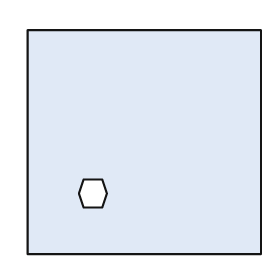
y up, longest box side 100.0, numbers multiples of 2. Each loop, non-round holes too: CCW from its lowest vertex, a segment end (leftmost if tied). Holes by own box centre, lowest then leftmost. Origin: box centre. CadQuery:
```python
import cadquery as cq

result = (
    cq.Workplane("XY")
    .moveTo(-50.0, -48.0)
    .lineTo(50.0, -48.0)
    .lineTo(50.0, 48.0)
    .lineTo(-50.0, 48.0)
    .close()
    .moveTo(-26.0, -28.0)
    .lineTo(-18.0, -28.0)
    .lineTo(-16.0, -22.0)
    .lineTo(-18.0, -16.0)
    .lineTo(-26.0, -16.0)
    .lineTo(-28.0, -22.0)
    .close()
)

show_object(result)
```